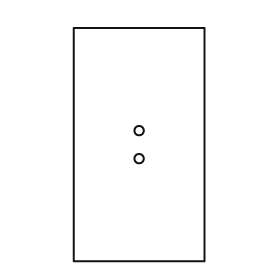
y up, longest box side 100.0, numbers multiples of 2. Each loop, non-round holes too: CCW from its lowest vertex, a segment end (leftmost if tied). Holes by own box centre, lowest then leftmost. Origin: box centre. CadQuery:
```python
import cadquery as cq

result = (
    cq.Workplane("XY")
    .moveTo(-28.0, -50.0)
    .lineTo(28.0, -50.0)
    .lineTo(28.0, 50.0)
    .lineTo(-28.0, 50.0)
    .close()
    .moveTo(0.0, -6.0)
    .circle(2.0)
    .moveTo(0.0, 6.0)
    .circle(2.0)
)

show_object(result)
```